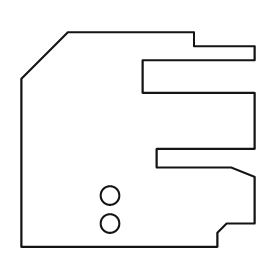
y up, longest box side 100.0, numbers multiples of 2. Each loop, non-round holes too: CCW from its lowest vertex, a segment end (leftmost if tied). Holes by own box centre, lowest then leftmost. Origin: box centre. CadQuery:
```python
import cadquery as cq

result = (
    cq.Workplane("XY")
    .moveTo(-50.0, -46.0)
    .lineTo(34.0, -46.0)
    .lineTo(34.0, -40.0)
    .lineTo(38.0, -36.0)
    .lineTo(50.0, -36.0)
    .lineTo(50.0, -16.0)
    .lineTo(40.0, -12.0)
    .lineTo(8.0, -12.0)
    .lineTo(8.0, -4.0)
    .lineTo(50.0, -4.0)
    .lineTo(50.0, 20.0)
    .lineTo(2.0, 20.0)
    .lineTo(2.0, 34.0)
    .lineTo(50.0, 34.0)
    .lineTo(50.0, 40.0)
    .lineTo(24.0, 40.0)
    .lineTo(24.0, 46.0)
    .lineTo(-30.0, 46.0)
    .lineTo(-50.0, 26.0)
    .close()
    .moveTo(-12.0, -36.0)
    .circle(4.0)
    .moveTo(-12.0, -24.0)
    .circle(4.0)
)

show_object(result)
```